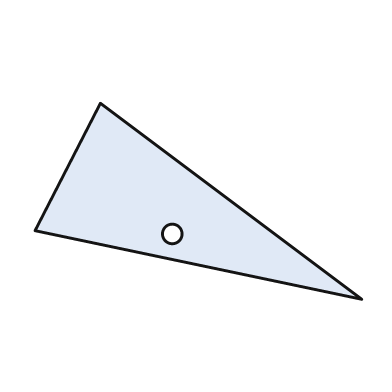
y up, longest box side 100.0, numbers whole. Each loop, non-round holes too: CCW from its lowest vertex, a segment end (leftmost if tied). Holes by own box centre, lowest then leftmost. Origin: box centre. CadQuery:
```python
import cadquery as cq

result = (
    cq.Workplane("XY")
    .moveTo(50.0, -30.0)
    .lineTo(-30.0, 30.0)
    .lineTo(-50.0, -9.0)
    .close()
    .moveTo(-8.0, -10.0)
    .circle(3.0)
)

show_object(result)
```